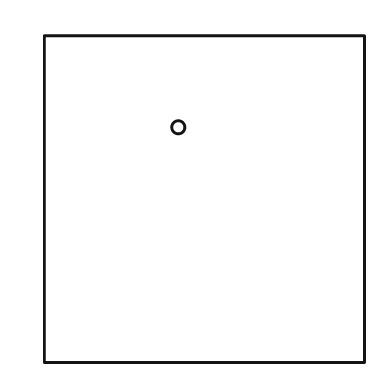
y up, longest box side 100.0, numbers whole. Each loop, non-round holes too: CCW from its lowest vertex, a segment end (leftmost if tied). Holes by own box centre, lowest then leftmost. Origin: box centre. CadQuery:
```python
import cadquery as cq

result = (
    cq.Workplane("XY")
    .moveTo(-49.0, -50.0)
    .lineTo(49.0, -50.0)
    .lineTo(49.0, 50.0)
    .lineTo(-49.0, 50.0)
    .close()
    .moveTo(-8.0, 22.0)
    .circle(2.0)
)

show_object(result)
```